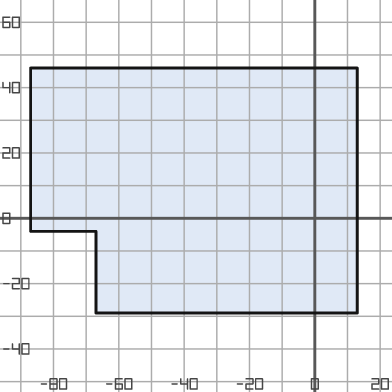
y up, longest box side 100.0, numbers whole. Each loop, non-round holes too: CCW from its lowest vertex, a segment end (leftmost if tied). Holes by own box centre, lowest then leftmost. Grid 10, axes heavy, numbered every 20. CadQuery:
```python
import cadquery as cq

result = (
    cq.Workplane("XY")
    .moveTo(-67.0, -29.0)
    .lineTo(13.0, -29.0)
    .lineTo(13.0, 46.0)
    .lineTo(-87.0, 46.0)
    .lineTo(-87.0, -4.0)
    .lineTo(-67.0, -4.0)
    .close()
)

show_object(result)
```